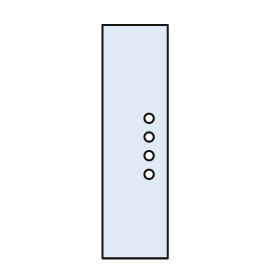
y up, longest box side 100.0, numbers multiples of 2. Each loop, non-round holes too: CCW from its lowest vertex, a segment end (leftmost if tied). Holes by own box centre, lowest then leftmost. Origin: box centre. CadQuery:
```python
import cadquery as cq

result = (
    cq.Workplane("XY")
    .moveTo(-14.0, -50.0)
    .lineTo(14.0, -50.0)
    .lineTo(14.0, 50.0)
    .lineTo(-14.0, 50.0)
    .close()
    .moveTo(6.0, -14.0)
    .circle(2.0)
    .moveTo(6.0, -6.0)
    .circle(2.0)
    .moveTo(6.0, 2.0)
    .circle(2.0)
    .moveTo(6.0, 10.0)
    .circle(2.0)
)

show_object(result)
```